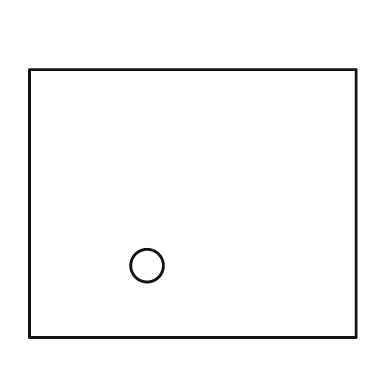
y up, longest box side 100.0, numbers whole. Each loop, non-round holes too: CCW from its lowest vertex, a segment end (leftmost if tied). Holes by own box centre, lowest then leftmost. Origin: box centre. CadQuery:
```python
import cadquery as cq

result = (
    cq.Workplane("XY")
    .moveTo(-50.0, -41.0)
    .lineTo(50.0, -41.0)
    .lineTo(50.0, 41.0)
    .lineTo(-50.0, 41.0)
    .close()
    .moveTo(-14.0, -19.0)
    .circle(5.0)
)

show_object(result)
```